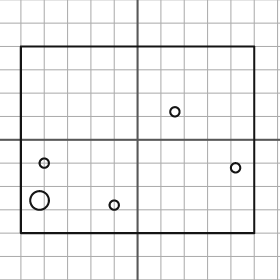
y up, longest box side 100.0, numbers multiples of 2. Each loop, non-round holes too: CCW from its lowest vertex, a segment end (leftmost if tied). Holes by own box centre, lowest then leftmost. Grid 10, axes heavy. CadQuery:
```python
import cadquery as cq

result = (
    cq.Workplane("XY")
    .moveTo(-50.0, -40.0)
    .lineTo(50.0, -40.0)
    .lineTo(50.0, 40.0)
    .lineTo(-50.0, 40.0)
    .close()
    .moveTo(-10.0, -28.0)
    .circle(2.0)
    .moveTo(-42.0, -26.0)
    .circle(4.0)
    .moveTo(42.0, -12.0)
    .circle(2.0)
    .moveTo(-40.0, -10.0)
    .circle(2.0)
    .moveTo(16.0, 12.0)
    .circle(2.0)
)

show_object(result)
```